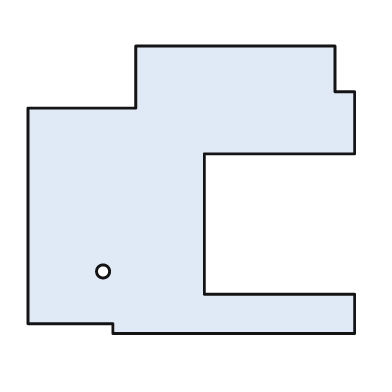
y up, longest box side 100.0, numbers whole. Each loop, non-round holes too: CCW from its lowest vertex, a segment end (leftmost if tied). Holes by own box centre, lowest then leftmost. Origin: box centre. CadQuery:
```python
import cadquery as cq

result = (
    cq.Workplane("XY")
    .moveTo(-24.0, -44.0)
    .lineTo(50.0, -44.0)
    .lineTo(50.0, -32.0)
    .lineTo(4.0, -32.0)
    .lineTo(4.0, 11.0)
    .lineTo(50.0, 11.0)
    .lineTo(50.0, 30.0)
    .lineTo(44.0, 30.0)
    .lineTo(44.0, 44.0)
    .lineTo(-17.0, 44.0)
    .lineTo(-17.0, 25.0)
    .lineTo(-50.0, 25.0)
    .lineTo(-50.0, -41.0)
    .lineTo(-24.0, -41.0)
    .close()
    .moveTo(-27.0, -25.0)
    .circle(2.0)
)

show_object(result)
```